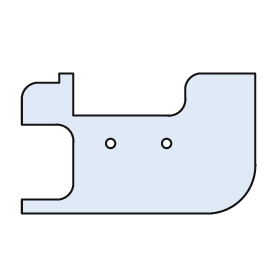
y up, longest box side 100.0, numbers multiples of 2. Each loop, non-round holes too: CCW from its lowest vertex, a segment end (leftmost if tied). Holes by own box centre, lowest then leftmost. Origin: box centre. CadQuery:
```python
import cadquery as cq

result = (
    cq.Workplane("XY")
    .moveTo(-50.0, -30.0)
    .lineTo(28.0, -30.0)
    .threePointArc((44.0, -24.0), (50.0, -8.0))
    .lineTo(50.0, 30.0)
    .lineTo(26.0, 30.0)
    .threePointArc((22.0, 28.0), (20.0, 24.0))
    .lineTo(20.0, 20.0)
    .threePointArc((18.0, 14.0), (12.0, 12.0))
    .lineTo(-28.0, 12.0)
    .lineTo(-28.0, 30.0)
    .lineTo(-34.0, 30.0)
    .lineTo(-34.0, 26.0)
    .lineTo(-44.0, 26.0)
    .threePointArc((-48.0, 24.0), (-50.0, 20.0))
    .lineTo(-50.0, 8.0)
    .lineTo(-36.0, 8.0)
    .threePointArc((-30.0, 6.0), (-28.0, 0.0))
    .lineTo(-28.0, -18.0)
    .threePointArc((-30.0, -22.0), (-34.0, -24.0))
    .lineTo(-50.0, -24.0)
    .close()
    .moveTo(-12.0, 0.0)
    .circle(2.0)
    .moveTo(12.0, 0.0)
    .circle(2.0)
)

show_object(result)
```